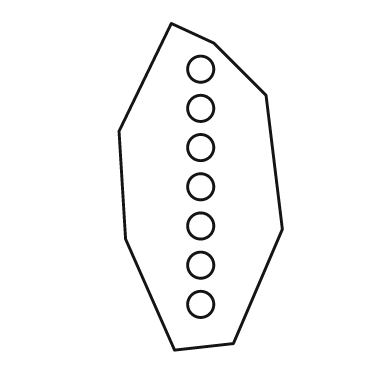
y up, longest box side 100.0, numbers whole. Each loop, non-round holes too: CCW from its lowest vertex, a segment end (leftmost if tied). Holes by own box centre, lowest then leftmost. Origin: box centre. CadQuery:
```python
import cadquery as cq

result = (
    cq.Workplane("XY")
    .moveTo(-8.0, -50.0)
    .lineTo(10.0, -48.0)
    .lineTo(25.0, -13.0)
    .lineTo(20.0, 28.0)
    .lineTo(4.0, 44.0)
    .lineTo(-9.0, 50.0)
    .lineTo(-25.0, 17.0)
    .lineTo(-23.0, -16.0)
    .close()
    .moveTo(0.0, -36.0)
    .circle(4.0)
    .moveTo(0.0, -24.0)
    .circle(4.0)
    .moveTo(0.0, -12.0)
    .circle(4.0)
    .moveTo(0.0, 0.0)
    .circle(4.0)
    .moveTo(0.0, 12.0)
    .circle(4.0)
    .moveTo(0.0, 24.0)
    .circle(4.0)
    .moveTo(0.0, 36.0)
    .circle(4.0)
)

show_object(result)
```